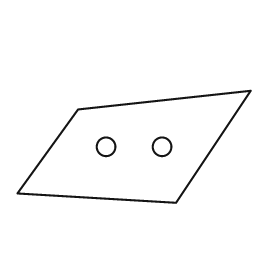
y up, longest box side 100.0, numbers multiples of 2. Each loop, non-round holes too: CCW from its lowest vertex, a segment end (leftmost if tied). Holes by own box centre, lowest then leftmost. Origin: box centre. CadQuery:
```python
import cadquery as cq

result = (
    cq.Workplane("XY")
    .moveTo(18.0, -24.0)
    .lineTo(50.0, 24.0)
    .lineTo(-24.0, 16.0)
    .lineTo(-50.0, -20.0)
    .close()
    .moveTo(-12.0, 0.0)
    .circle(4.0)
    .moveTo(12.0, 0.0)
    .circle(4.0)
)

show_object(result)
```